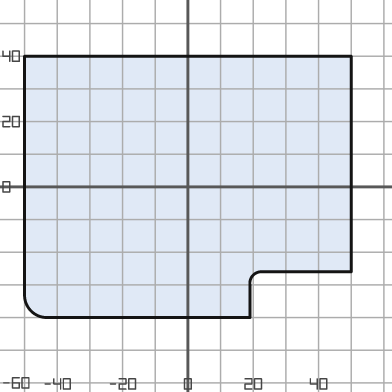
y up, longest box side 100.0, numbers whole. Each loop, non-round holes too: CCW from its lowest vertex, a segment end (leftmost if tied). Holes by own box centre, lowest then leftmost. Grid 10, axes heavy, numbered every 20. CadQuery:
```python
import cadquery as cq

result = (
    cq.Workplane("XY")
    .moveTo(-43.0, -40.0)
    .lineTo(19.0, -40.0)
    .lineTo(19.0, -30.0)
    .threePointArc((20.0, -27.0), (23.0, -26.0))
    .lineTo(50.0, -26.0)
    .lineTo(50.0, 40.0)
    .lineTo(-50.0, 40.0)
    .lineTo(-50.0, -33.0)
    .threePointArc((-48.0, -38.0), (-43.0, -40.0))
    .close()
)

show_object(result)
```